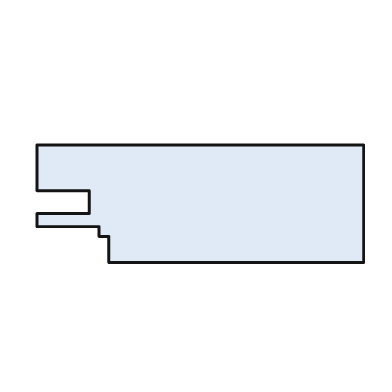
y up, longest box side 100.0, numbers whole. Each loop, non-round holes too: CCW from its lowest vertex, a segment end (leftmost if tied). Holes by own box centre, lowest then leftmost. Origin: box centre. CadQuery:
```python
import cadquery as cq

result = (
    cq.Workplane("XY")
    .moveTo(-28.0, -18.0)
    .lineTo(50.0, -18.0)
    .lineTo(50.0, 18.0)
    .lineTo(-50.0, 18.0)
    .lineTo(-50.0, 4.0)
    .lineTo(-34.0, 4.0)
    .lineTo(-34.0, -3.0)
    .lineTo(-50.0, -3.0)
    .lineTo(-50.0, -7.0)
    .lineTo(-31.0, -7.0)
    .lineTo(-31.0, -10.0)
    .lineTo(-28.0, -10.0)
    .close()
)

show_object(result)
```